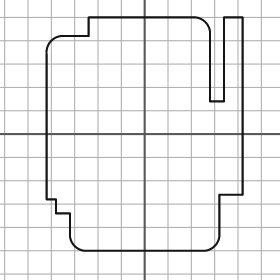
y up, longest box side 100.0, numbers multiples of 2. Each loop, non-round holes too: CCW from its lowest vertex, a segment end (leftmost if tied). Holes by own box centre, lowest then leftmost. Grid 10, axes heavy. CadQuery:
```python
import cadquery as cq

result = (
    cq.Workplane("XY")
    .moveTo(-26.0, -50.0)
    .lineTo(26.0, -50.0)
    .threePointArc((30.0, -48.0), (32.0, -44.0))
    .lineTo(32.0, -26.0)
    .lineTo(42.0, -26.0)
    .lineTo(42.0, 50.0)
    .lineTo(34.0, 50.0)
    .lineTo(34.0, 14.0)
    .lineTo(28.0, 14.0)
    .lineTo(28.0, 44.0)
    .threePointArc((26.0, 48.0), (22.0, 50.0))
    .lineTo(-24.0, 50.0)
    .lineTo(-24.0, 42.0)
    .lineTo(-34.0, 42.0)
    .threePointArc((-40.0, 40.0), (-42.0, 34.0))
    .lineTo(-42.0, -28.0)
    .lineTo(-38.0, -28.0)
    .lineTo(-38.0, -34.0)
    .lineTo(-32.0, -34.0)
    .lineTo(-32.0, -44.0)
    .threePointArc((-30.0, -48.0), (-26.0, -50.0))
    .close()
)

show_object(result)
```